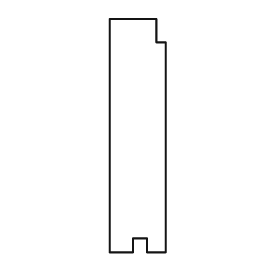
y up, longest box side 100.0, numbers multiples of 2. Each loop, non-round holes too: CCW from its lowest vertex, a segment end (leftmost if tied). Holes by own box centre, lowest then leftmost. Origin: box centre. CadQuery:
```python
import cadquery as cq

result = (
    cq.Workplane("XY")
    .moveTo(-12.0, -50.0)
    .lineTo(-2.0, -50.0)
    .lineTo(-2.0, -44.0)
    .lineTo(4.0, -44.0)
    .lineTo(4.0, -50.0)
    .lineTo(12.0, -50.0)
    .lineTo(12.0, 40.0)
    .lineTo(8.0, 40.0)
    .lineTo(8.0, 50.0)
    .lineTo(-12.0, 50.0)
    .close()
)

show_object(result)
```